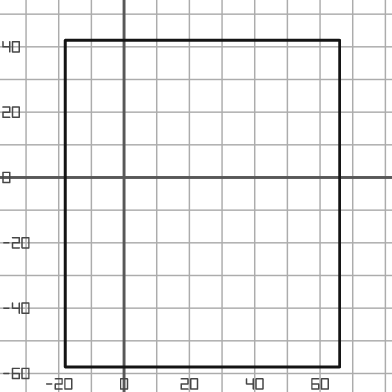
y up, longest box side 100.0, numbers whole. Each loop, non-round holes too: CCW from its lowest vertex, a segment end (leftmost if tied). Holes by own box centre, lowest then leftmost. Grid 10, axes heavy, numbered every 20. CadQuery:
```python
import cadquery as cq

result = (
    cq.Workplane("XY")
    .moveTo(-18.0, -58.0)
    .lineTo(66.0, -58.0)
    .lineTo(66.0, 42.0)
    .lineTo(-18.0, 42.0)
    .close()
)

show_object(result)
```